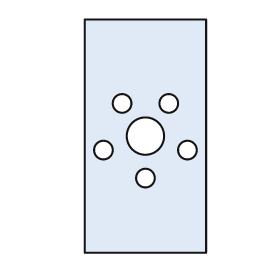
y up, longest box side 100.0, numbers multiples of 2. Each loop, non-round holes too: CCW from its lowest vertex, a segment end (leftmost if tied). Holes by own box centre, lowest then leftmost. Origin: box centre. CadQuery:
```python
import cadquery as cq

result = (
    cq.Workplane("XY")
    .moveTo(-26.0, -50.0)
    .lineTo(26.0, -50.0)
    .lineTo(26.0, 50.0)
    .lineTo(-26.0, 50.0)
    .close()
    .moveTo(0.0, -18.0)
    .circle(4.0)
    .moveTo(-18.0, -6.0)
    .circle(4.0)
    .moveTo(18.0, -6.0)
    .circle(4.0)
    .moveTo(0.0, 0.0)
    .circle(8.0)
    .moveTo(-10.0, 14.0)
    .circle(4.0)
    .moveTo(10.0, 14.0)
    .circle(4.0)
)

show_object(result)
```